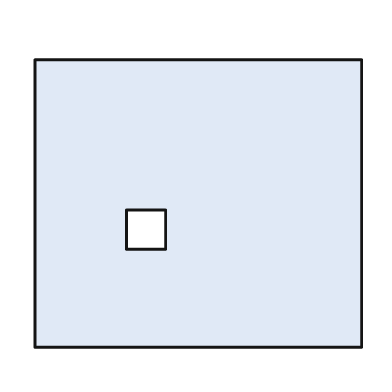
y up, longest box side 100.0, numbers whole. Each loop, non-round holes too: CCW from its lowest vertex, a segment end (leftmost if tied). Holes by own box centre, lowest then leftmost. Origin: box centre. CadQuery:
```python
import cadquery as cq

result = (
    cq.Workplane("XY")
    .moveTo(-50.0, -44.0)
    .lineTo(50.0, -44.0)
    .lineTo(50.0, 44.0)
    .lineTo(-50.0, 44.0)
    .close()
    .moveTo(-22.0, -14.0)
    .lineTo(-10.0, -14.0)
    .lineTo(-10.0, -2.0)
    .lineTo(-22.0, -2.0)
    .close()
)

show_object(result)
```